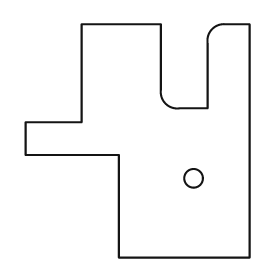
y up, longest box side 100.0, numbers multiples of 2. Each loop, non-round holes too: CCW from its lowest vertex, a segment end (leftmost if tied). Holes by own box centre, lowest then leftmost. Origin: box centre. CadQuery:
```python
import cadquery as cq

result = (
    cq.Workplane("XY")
    .moveTo(-8.0, -50.0)
    .lineTo(48.0, -50.0)
    .lineTo(48.0, 50.0)
    .lineTo(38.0, 50.0)
    .threePointArc((32.0, 48.0), (30.0, 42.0))
    .lineTo(30.0, 14.0)
    .lineTo(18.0, 14.0)
    .threePointArc((12.0, 16.0), (10.0, 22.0))
    .lineTo(10.0, 50.0)
    .lineTo(-24.0, 50.0)
    .lineTo(-24.0, 8.0)
    .lineTo(-48.0, 8.0)
    .lineTo(-48.0, -6.0)
    .lineTo(-8.0, -6.0)
    .close()
    .moveTo(24.0, -16.0)
    .circle(4.0)
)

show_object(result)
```